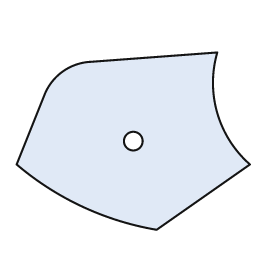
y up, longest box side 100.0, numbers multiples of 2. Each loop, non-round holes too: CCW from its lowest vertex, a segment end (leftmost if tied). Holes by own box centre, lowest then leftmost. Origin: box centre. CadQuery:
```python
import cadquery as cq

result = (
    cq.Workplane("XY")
    .moveTo(10.0, -38.0)
    .lineTo(50.0, -10.0)
    .threePointArc((36.0, 12.0), (36.0, 38.0))
    .lineTo(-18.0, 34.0)
    .threePointArc((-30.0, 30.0), (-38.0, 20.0))
    .lineTo(-50.0, -10.0)
    .threePointArc((-22.0, -28.0), (10.0, -38.0))
    .close()
    .moveTo(0.0, 0.0)
    .circle(4.0)
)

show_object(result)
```